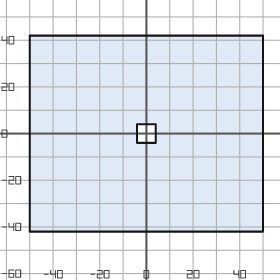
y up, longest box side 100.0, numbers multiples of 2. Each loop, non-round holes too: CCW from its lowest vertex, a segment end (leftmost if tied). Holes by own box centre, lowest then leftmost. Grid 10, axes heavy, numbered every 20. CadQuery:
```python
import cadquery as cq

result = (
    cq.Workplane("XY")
    .moveTo(-50.0, -42.0)
    .lineTo(50.0, -42.0)
    .lineTo(50.0, 42.0)
    .lineTo(-50.0, 42.0)
    .close()
    .moveTo(-4.0, -4.0)
    .lineTo(4.0, -4.0)
    .lineTo(4.0, 4.0)
    .lineTo(-4.0, 4.0)
    .close()
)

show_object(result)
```